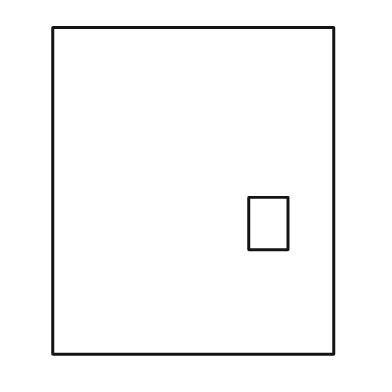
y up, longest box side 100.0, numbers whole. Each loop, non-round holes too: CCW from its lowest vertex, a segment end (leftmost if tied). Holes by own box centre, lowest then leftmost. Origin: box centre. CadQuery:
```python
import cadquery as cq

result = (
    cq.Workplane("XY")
    .moveTo(-43.0, -50.0)
    .lineTo(43.0, -50.0)
    .lineTo(43.0, 50.0)
    .lineTo(-43.0, 50.0)
    .close()
    .moveTo(17.0, -18.0)
    .lineTo(29.0, -18.0)
    .lineTo(29.0, -2.0)
    .lineTo(17.0, -2.0)
    .close()
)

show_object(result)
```